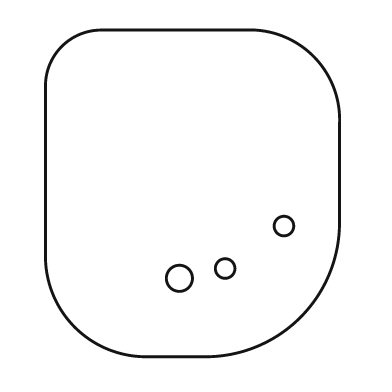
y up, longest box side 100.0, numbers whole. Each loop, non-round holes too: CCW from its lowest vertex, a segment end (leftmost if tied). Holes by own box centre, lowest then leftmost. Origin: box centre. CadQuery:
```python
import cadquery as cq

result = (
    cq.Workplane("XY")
    .moveTo(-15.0, -50.0)
    .lineTo(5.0, -50.0)
    .threePointArc((33.0, -38.0), (45.0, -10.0))
    .lineTo(45.0, 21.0)
    .threePointArc((37.0, 42.0), (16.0, 50.0))
    .lineTo(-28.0, 50.0)
    .threePointArc((-40.0, 45.0), (-45.0, 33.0))
    .lineTo(-45.0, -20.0)
    .threePointArc((-36.0, -41.0), (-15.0, -50.0))
    .close()
    .moveTo(-4.0, -26.0)
    .circle(4.0)
    .moveTo(10.0, -23.0)
    .circle(3.0)
    .moveTo(28.0, -10.0)
    .circle(3.0)
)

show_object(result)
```